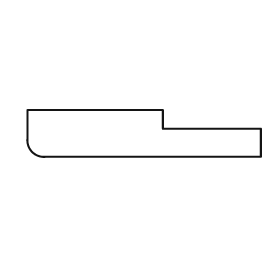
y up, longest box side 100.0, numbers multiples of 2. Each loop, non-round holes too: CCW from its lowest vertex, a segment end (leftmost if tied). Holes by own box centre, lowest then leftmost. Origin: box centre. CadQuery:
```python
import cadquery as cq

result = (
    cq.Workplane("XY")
    .moveTo(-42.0, -10.0)
    .lineTo(50.0, -10.0)
    .lineTo(50.0, 2.0)
    .lineTo(8.0, 2.0)
    .lineTo(8.0, 10.0)
    .lineTo(-50.0, 10.0)
    .lineTo(-50.0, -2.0)
    .threePointArc((-48.0, -8.0), (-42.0, -10.0))
    .close()
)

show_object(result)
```